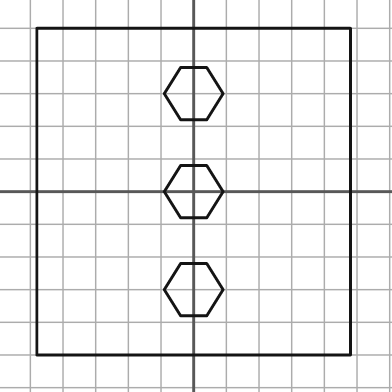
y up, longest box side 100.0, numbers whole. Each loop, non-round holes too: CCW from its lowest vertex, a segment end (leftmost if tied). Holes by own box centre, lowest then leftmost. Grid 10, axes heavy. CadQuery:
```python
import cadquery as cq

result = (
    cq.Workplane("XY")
    .moveTo(-48.0, -50.0)
    .lineTo(48.0, -50.0)
    .lineTo(48.0, 50.0)
    .lineTo(-48.0, 50.0)
    .close()
    .moveTo(-4.0, -38.0)
    .lineTo(4.0, -38.0)
    .lineTo(9.0, -30.0)
    .lineTo(4.0, -22.0)
    .lineTo(-4.0, -22.0)
    .lineTo(-9.0, -30.0)
    .close()
    .moveTo(-4.0, -8.0)
    .lineTo(4.0, -8.0)
    .lineTo(9.0, 0.0)
    .lineTo(4.0, 8.0)
    .lineTo(-4.0, 8.0)
    .lineTo(-9.0, 0.0)
    .close()
    .moveTo(-4.0, 22.0)
    .lineTo(4.0, 22.0)
    .lineTo(9.0, 30.0)
    .lineTo(4.0, 38.0)
    .lineTo(-4.0, 38.0)
    .lineTo(-9.0, 30.0)
    .close()
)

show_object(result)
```